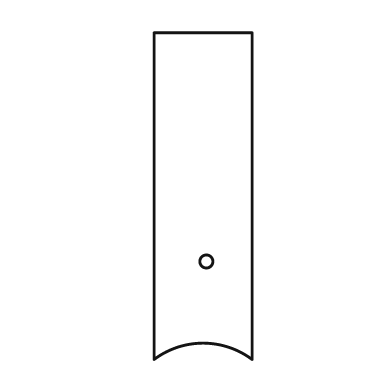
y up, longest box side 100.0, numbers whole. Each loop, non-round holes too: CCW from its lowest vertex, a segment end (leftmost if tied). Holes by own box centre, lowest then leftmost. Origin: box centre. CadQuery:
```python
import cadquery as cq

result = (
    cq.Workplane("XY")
    .moveTo(-15.0, -50.0)
    .threePointArc((0.0, -45.0), (15.0, -50.0))
    .lineTo(15.0, 50.0)
    .lineTo(-15.0, 50.0)
    .close()
    .moveTo(1.0, -20.0)
    .circle(2.0)
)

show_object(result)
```